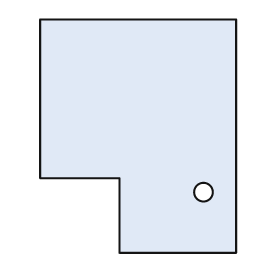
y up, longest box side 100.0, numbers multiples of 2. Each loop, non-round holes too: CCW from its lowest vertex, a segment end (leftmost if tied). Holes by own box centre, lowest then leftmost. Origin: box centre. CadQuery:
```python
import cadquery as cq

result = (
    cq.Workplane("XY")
    .moveTo(-8.0, -50.0)
    .lineTo(42.0, -50.0)
    .lineTo(42.0, 50.0)
    .lineTo(-42.0, 50.0)
    .lineTo(-42.0, -18.0)
    .lineTo(-8.0, -18.0)
    .close()
    .moveTo(28.0, -24.0)
    .circle(4.0)
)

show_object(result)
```